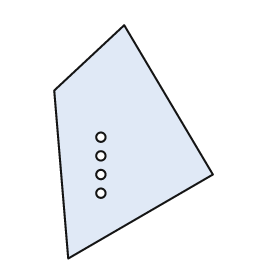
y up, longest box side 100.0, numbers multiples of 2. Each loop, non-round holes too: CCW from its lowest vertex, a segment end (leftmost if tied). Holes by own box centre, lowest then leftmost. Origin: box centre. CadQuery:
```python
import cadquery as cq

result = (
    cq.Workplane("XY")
    .moveTo(-28.0, -50.0)
    .lineTo(34.0, -14.0)
    .lineTo(-4.0, 50.0)
    .lineTo(-34.0, 22.0)
    .close()
    .moveTo(-14.0, -22.0)
    .circle(2.0)
    .moveTo(-14.0, -14.0)
    .circle(2.0)
    .moveTo(-14.0, -6.0)
    .circle(2.0)
    .moveTo(-14.0, 2.0)
    .circle(2.0)
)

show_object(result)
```